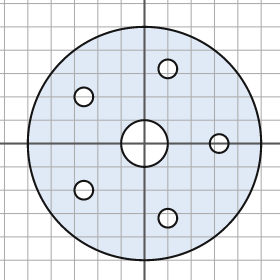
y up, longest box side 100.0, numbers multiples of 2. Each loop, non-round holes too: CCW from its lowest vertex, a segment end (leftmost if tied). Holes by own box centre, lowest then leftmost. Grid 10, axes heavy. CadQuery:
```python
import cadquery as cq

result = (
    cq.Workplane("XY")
    .moveTo(0.0, 0.0)
    .circle(50.0)
    .moveTo(10.0, -32.0)
    .circle(4.0)
    .moveTo(-26.0, -20.0)
    .circle(4.0)
    .moveTo(0.0, 0.0)
    .circle(10.0)
    .moveTo(32.0, 0.0)
    .circle(4.0)
    .moveTo(-26.0, 20.0)
    .circle(4.0)
    .moveTo(10.0, 32.0)
    .circle(4.0)
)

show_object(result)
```